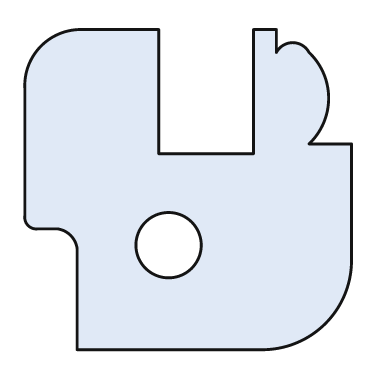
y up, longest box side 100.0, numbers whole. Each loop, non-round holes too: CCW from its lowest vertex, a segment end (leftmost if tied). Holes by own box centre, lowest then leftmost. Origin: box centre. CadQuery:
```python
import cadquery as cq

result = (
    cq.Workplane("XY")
    .moveTo(-34.0, -49.0)
    .lineTo(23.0, -49.0)
    .threePointArc((42.0, -41.0), (50.0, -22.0))
    .lineTo(50.0, 14.0)
    .lineTo(37.0, 14.0)
    .threePointArc((43.0, 28.0), (37.0, 42.0))
    .threePointArc((32.0, 45.0), (27.0, 42.0))
    .lineTo(27.0, 49.0)
    .lineTo(20.0, 49.0)
    .lineTo(20.0, 11.0)
    .lineTo(-9.0, 11.0)
    .lineTo(-9.0, 49.0)
    .lineTo(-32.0, 49.0)
    .threePointArc((-45.0, 44.0), (-50.0, 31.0))
    .lineTo(-50.0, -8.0)
    .threePointArc((-49.0, -11.0), (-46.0, -12.0))
    .lineTo(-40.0, -12.0)
    .threePointArc((-36.0, -14.0), (-34.0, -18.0))
    .close()
    .moveTo(-6.0, -17.0)
    .circle(10.0)
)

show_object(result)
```